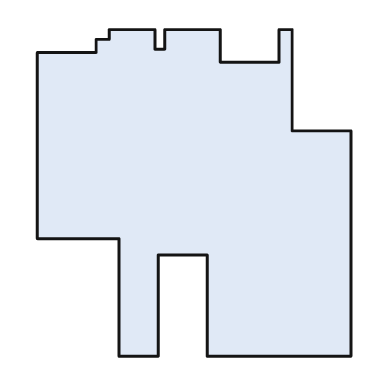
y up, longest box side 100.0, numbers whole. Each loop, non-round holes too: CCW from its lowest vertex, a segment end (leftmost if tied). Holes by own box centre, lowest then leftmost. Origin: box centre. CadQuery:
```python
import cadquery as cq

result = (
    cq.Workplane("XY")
    .moveTo(-23.0, -50.0)
    .lineTo(-11.0, -50.0)
    .lineTo(-11.0, -19.0)
    .lineTo(4.0, -19.0)
    .lineTo(4.0, -50.0)
    .lineTo(48.0, -50.0)
    .lineTo(48.0, 19.0)
    .lineTo(30.0, 19.0)
    .lineTo(30.0, 50.0)
    .lineTo(26.0, 50.0)
    .lineTo(26.0, 40.0)
    .lineTo(8.0, 40.0)
    .lineTo(8.0, 50.0)
    .lineTo(-9.0, 50.0)
    .lineTo(-9.0, 44.0)
    .lineTo(-12.0, 44.0)
    .lineTo(-12.0, 50.0)
    .lineTo(-26.0, 50.0)
    .lineTo(-26.0, 47.0)
    .lineTo(-30.0, 47.0)
    .lineTo(-30.0, 43.0)
    .lineTo(-48.0, 43.0)
    .lineTo(-48.0, -14.0)
    .lineTo(-23.0, -14.0)
    .close()
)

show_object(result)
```